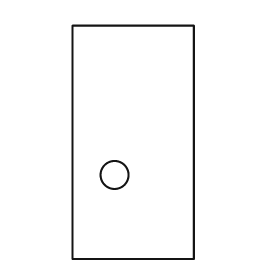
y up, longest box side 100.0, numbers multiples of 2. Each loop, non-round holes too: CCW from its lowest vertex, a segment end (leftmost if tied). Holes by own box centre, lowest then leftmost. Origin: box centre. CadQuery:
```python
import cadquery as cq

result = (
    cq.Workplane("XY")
    .moveTo(-26.0, -50.0)
    .lineTo(26.0, -50.0)
    .lineTo(26.0, 50.0)
    .lineTo(-26.0, 50.0)
    .close()
    .moveTo(-8.0, -14.0)
    .circle(6.0)
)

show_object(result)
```